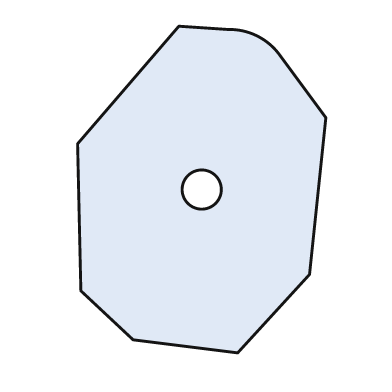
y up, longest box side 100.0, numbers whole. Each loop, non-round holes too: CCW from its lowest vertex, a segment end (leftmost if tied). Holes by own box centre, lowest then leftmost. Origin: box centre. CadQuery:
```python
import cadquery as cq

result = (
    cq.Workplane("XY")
    .moveTo(11.0, -50.0)
    .lineTo(33.0, -26.0)
    .lineTo(38.0, 22.0)
    .lineTo(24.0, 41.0)
    .threePointArc((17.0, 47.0), (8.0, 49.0))
    .lineTo(-7.0, 50.0)
    .lineTo(-38.0, 14.0)
    .lineTo(-37.0, -31.0)
    .lineTo(-21.0, -46.0)
    .close()
    .moveTo(0.0, 0.0)
    .circle(6.0)
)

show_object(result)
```